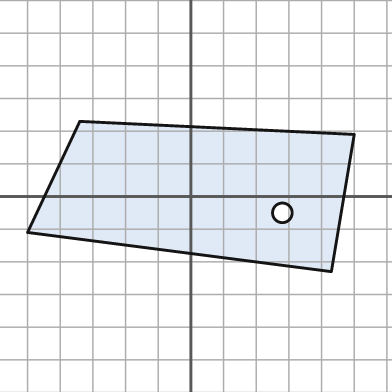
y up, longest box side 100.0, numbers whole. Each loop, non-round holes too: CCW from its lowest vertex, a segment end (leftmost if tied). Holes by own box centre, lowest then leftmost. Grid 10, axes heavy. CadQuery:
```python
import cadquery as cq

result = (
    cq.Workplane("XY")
    .moveTo(43.0, -23.0)
    .lineTo(50.0, 19.0)
    .lineTo(-34.0, 23.0)
    .lineTo(-50.0, -11.0)
    .close()
    .moveTo(28.0, -5.0)
    .circle(3.0)
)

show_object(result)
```